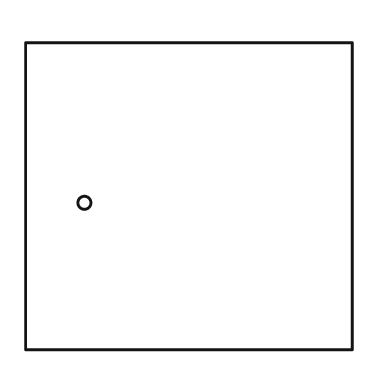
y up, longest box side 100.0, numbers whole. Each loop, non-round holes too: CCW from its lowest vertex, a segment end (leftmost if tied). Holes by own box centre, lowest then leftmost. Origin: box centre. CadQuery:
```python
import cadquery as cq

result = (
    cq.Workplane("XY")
    .moveTo(-50.0, -47.0)
    .lineTo(50.0, -47.0)
    .lineTo(50.0, 47.0)
    .lineTo(-50.0, 47.0)
    .close()
    .moveTo(-32.0, -2.0)
    .circle(2.0)
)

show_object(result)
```